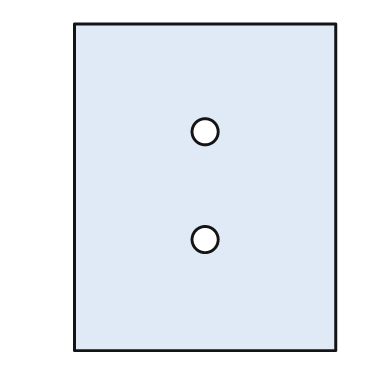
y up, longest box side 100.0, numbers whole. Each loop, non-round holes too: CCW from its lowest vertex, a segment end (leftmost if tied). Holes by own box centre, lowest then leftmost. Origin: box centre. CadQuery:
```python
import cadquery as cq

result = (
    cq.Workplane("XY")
    .moveTo(-40.0, -50.0)
    .lineTo(40.0, -50.0)
    .lineTo(40.0, 50.0)
    .lineTo(-40.0, 50.0)
    .close()
    .moveTo(0.0, -16.0)
    .circle(4.0)
    .moveTo(0.0, 17.0)
    .circle(4.0)
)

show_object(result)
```